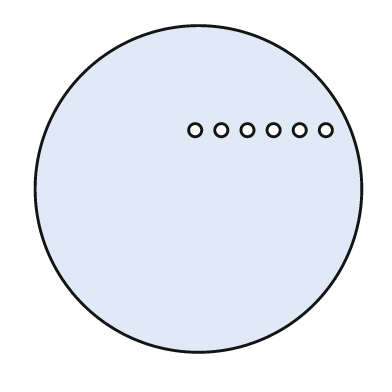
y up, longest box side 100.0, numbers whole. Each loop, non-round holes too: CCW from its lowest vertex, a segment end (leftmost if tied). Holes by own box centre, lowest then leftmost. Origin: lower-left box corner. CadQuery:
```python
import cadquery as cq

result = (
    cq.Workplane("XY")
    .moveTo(50.0, 50.0)
    .circle(50.0)
    .moveTo(49.0, 68.0)
    .circle(2.0)
    .moveTo(57.0, 68.0)
    .circle(2.0)
    .moveTo(65.0, 68.0)
    .circle(2.0)
    .moveTo(73.0, 68.0)
    .circle(2.0)
    .moveTo(81.0, 68.0)
    .circle(2.0)
    .moveTo(89.0, 68.0)
    .circle(2.0)
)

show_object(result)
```